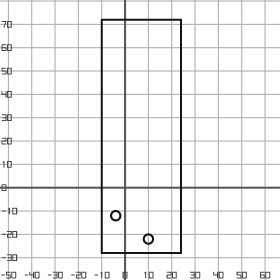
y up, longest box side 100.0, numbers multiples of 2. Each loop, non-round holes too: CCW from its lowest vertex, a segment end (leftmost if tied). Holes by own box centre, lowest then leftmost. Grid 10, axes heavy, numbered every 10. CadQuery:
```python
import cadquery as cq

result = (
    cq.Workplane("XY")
    .moveTo(-10.0, -28.0)
    .lineTo(24.0, -28.0)
    .lineTo(24.0, 72.0)
    .lineTo(-10.0, 72.0)
    .close()
    .moveTo(10.0, -22.0)
    .circle(2.0)
    .moveTo(-4.0, -12.0)
    .circle(2.0)
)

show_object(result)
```